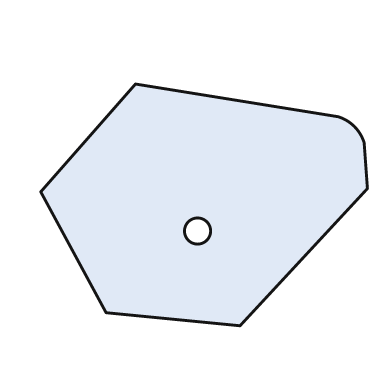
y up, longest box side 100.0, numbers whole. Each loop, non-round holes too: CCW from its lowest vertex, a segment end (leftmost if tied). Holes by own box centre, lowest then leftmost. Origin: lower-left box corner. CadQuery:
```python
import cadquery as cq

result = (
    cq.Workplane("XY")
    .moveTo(61.0, 0.0)
    .lineTo(100.0, 42.0)
    .lineTo(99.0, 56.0)
    .threePointArc((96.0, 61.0), (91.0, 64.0))
    .lineTo(29.0, 74.0)
    .lineTo(0.0, 41.0)
    .lineTo(20.0, 4.0)
    .close()
    .moveTo(48.0, 29.0)
    .circle(4.0)
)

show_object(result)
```